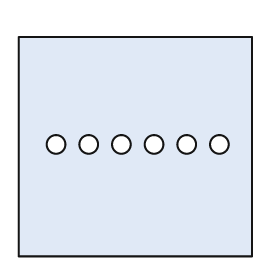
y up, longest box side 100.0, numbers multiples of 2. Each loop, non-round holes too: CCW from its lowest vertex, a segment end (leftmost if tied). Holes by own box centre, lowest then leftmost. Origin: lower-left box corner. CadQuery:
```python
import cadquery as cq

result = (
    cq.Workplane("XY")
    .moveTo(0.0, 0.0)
    .lineTo(100.0, 0.0)
    .lineTo(100.0, 94.0)
    .lineTo(0.0, 94.0)
    .close()
    .moveTo(16.0, 48.0)
    .circle(4.0)
    .moveTo(30.0, 48.0)
    .circle(4.0)
    .moveTo(44.0, 48.0)
    .circle(4.0)
    .moveTo(58.0, 48.0)
    .circle(4.0)
    .moveTo(72.0, 48.0)
    .circle(4.0)
    .moveTo(86.0, 48.0)
    .circle(4.0)
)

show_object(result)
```